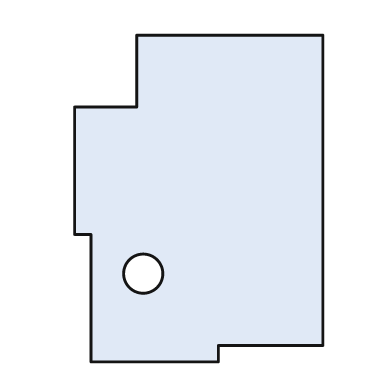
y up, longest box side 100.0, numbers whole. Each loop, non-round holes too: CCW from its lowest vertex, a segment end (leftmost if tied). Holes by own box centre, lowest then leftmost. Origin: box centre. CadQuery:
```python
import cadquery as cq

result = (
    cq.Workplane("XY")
    .moveTo(-33.0, -50.0)
    .lineTo(6.0, -50.0)
    .lineTo(6.0, -45.0)
    .lineTo(38.0, -45.0)
    .lineTo(38.0, 50.0)
    .lineTo(-19.0, 50.0)
    .lineTo(-19.0, 28.0)
    .lineTo(-38.0, 28.0)
    .lineTo(-38.0, -11.0)
    .lineTo(-33.0, -11.0)
    .close()
    .moveTo(-17.0, -23.0)
    .circle(6.0)
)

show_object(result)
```